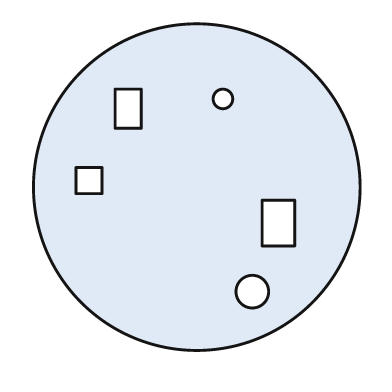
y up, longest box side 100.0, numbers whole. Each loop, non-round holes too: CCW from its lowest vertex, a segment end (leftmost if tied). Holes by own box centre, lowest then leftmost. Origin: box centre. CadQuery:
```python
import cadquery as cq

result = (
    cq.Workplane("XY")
    .moveTo(0.0, 0.0)
    .circle(50.0)
    .moveTo(17.0, -32.0)
    .circle(5.0)
    .moveTo(20.0, -18.0)
    .lineTo(30.0, -18.0)
    .lineTo(30.0, -4.0)
    .lineTo(20.0, -4.0)
    .close()
    .moveTo(-37.0, -2.0)
    .lineTo(-29.0, -2.0)
    .lineTo(-29.0, 6.0)
    .lineTo(-37.0, 6.0)
    .close()
    .moveTo(-25.0, 18.0)
    .lineTo(-17.0, 18.0)
    .lineTo(-17.0, 30.0)
    .lineTo(-25.0, 30.0)
    .close()
    .moveTo(8.0, 27.0)
    .circle(3.0)
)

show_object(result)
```